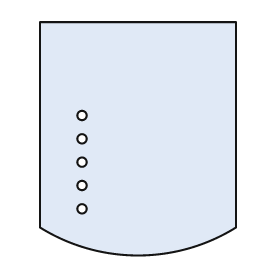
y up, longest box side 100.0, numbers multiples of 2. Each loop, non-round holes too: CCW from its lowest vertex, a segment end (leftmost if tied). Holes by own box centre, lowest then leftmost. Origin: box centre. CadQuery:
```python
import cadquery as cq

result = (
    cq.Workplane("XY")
    .moveTo(-42.0, -38.0)
    .threePointArc((0.0, -50.0), (42.0, -38.0))
    .lineTo(42.0, 50.0)
    .lineTo(-42.0, 50.0)
    .close()
    .moveTo(-24.0, -30.0)
    .circle(2.0)
    .moveTo(-24.0, -20.0)
    .circle(2.0)
    .moveTo(-24.0, -10.0)
    .circle(2.0)
    .moveTo(-24.0, 0.0)
    .circle(2.0)
    .moveTo(-24.0, 10.0)
    .circle(2.0)
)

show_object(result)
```